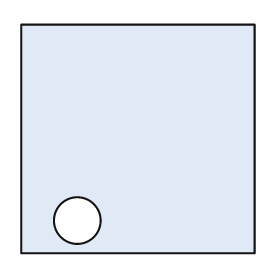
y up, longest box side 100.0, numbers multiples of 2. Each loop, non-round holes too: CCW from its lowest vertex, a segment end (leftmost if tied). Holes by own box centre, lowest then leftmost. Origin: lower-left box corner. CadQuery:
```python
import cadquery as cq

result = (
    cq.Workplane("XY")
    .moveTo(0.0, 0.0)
    .lineTo(100.0, 0.0)
    .lineTo(100.0, 98.0)
    .lineTo(0.0, 98.0)
    .close()
    .moveTo(24.0, 14.0)
    .circle(10.0)
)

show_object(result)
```